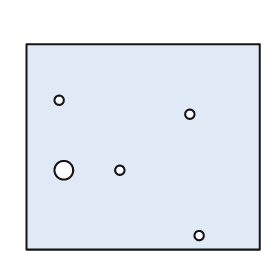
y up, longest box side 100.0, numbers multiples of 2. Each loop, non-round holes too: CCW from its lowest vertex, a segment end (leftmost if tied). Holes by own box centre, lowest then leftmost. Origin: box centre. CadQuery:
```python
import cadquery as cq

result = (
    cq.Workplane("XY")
    .moveTo(-50.0, -44.0)
    .lineTo(50.0, -44.0)
    .lineTo(50.0, 44.0)
    .lineTo(-50.0, 44.0)
    .close()
    .moveTo(24.0, -38.0)
    .circle(2.0)
    .moveTo(-34.0, -10.0)
    .circle(4.0)
    .moveTo(-10.0, -10.0)
    .circle(2.0)
    .moveTo(20.0, 14.0)
    .circle(2.0)
    .moveTo(-36.0, 20.0)
    .circle(2.0)
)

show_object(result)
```